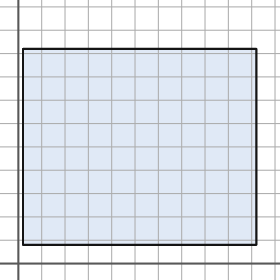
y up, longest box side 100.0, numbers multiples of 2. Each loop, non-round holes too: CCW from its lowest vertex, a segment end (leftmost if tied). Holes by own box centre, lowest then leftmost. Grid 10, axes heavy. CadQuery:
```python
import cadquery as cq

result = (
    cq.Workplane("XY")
    .moveTo(2.0, 8.0)
    .lineTo(102.0, 8.0)
    .lineTo(102.0, 92.0)
    .lineTo(2.0, 92.0)
    .close()
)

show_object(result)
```